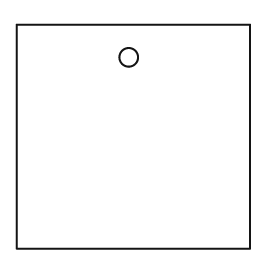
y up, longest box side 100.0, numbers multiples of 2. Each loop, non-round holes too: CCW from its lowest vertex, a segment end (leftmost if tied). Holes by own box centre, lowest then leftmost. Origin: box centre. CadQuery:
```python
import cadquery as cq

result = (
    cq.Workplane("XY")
    .moveTo(-50.0, -48.0)
    .lineTo(50.0, -48.0)
    .lineTo(50.0, 48.0)
    .lineTo(-50.0, 48.0)
    .close()
    .moveTo(-2.0, 34.0)
    .circle(4.0)
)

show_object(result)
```